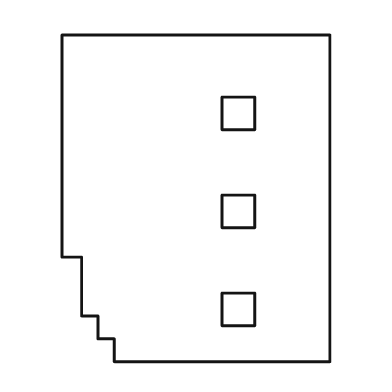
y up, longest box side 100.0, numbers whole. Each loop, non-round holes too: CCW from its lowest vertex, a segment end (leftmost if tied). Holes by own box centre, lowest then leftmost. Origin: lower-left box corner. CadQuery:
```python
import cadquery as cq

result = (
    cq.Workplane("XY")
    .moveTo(16.0, 0.0)
    .lineTo(82.0, 0.0)
    .lineTo(82.0, 100.0)
    .lineTo(0.0, 100.0)
    .lineTo(0.0, 32.0)
    .lineTo(6.0, 32.0)
    .lineTo(6.0, 14.0)
    .lineTo(11.0, 14.0)
    .lineTo(11.0, 7.0)
    .lineTo(16.0, 7.0)
    .close()
    .moveTo(49.0, 11.0)
    .lineTo(59.0, 11.0)
    .lineTo(59.0, 21.0)
    .lineTo(49.0, 21.0)
    .close()
    .moveTo(49.0, 41.0)
    .lineTo(59.0, 41.0)
    .lineTo(59.0, 51.0)
    .lineTo(49.0, 51.0)
    .close()
    .moveTo(49.0, 71.0)
    .lineTo(59.0, 71.0)
    .lineTo(59.0, 81.0)
    .lineTo(49.0, 81.0)
    .close()
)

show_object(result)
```